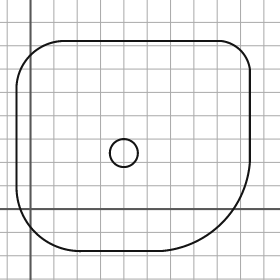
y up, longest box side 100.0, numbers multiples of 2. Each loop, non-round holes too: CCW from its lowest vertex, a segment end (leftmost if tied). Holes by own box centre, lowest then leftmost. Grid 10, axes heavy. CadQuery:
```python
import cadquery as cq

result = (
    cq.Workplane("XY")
    .moveTo(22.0, -18.0)
    .lineTo(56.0, -18.0)
    .threePointArc((82.0, -6.0), (94.0, 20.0))
    .lineTo(94.0, 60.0)
    .threePointArc((90.0, 68.0), (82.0, 72.0))
    .lineTo(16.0, 72.0)
    .threePointArc((0.0, 66.0), (-6.0, 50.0))
    .lineTo(-6.0, 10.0)
    .threePointArc((2.0, -10.0), (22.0, -18.0))
    .close()
    .moveTo(40.0, 24.0)
    .circle(6.0)
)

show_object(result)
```